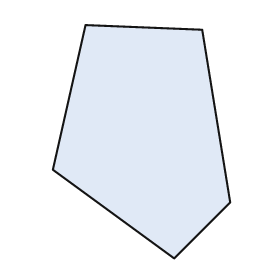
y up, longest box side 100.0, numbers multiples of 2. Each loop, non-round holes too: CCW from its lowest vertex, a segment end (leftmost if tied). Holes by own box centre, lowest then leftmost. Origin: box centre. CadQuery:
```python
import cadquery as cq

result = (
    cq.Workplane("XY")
    .moveTo(14.0, -50.0)
    .lineTo(38.0, -26.0)
    .lineTo(26.0, 48.0)
    .lineTo(-24.0, 50.0)
    .lineTo(-38.0, -12.0)
    .close()
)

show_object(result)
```